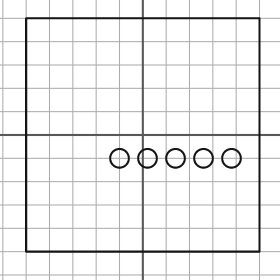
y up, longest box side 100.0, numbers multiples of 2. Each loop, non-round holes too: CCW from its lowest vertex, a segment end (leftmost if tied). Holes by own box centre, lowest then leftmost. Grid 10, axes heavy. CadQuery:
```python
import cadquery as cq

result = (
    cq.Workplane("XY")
    .moveTo(-50.0, -50.0)
    .lineTo(50.0, -50.0)
    .lineTo(50.0, 50.0)
    .lineTo(-50.0, 50.0)
    .close()
    .moveTo(-10.0, -10.0)
    .circle(4.0)
    .moveTo(2.0, -10.0)
    .circle(4.0)
    .moveTo(14.0, -10.0)
    .circle(4.0)
    .moveTo(26.0, -10.0)
    .circle(4.0)
    .moveTo(38.0, -10.0)
    .circle(4.0)
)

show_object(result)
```